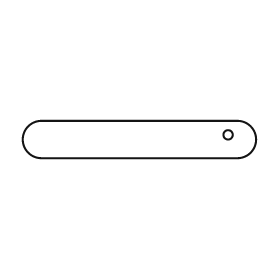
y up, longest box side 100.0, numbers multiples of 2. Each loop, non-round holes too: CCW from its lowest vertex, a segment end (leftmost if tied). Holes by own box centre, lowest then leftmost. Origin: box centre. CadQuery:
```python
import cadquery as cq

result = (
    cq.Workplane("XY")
    .moveTo(-42.0, -8.0)
    .lineTo(42.0, -8.0)
    .threePointArc((50.0, 0.0), (42.0, 8.0))
    .lineTo(-42.0, 8.0)
    .threePointArc((-50.0, 0.0), (-42.0, -8.0))
    .close()
    .moveTo(38.0, 2.0)
    .circle(2.0)
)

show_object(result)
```